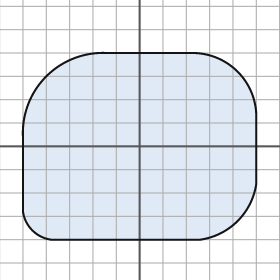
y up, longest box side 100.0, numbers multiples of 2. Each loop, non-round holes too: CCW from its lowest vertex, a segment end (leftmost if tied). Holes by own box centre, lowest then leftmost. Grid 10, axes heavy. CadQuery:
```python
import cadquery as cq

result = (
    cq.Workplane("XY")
    .moveTo(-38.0, -40.0)
    .lineTo(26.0, -40.0)
    .threePointArc((42.0, -32.0), (50.0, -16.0))
    .lineTo(50.0, 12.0)
    .threePointArc((42.0, 32.0), (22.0, 40.0))
    .lineTo(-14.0, 40.0)
    .threePointArc((-40.0, 30.0), (-50.0, 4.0))
    .lineTo(-50.0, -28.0)
    .threePointArc((-46.0, -36.0), (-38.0, -40.0))
    .close()
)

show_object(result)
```